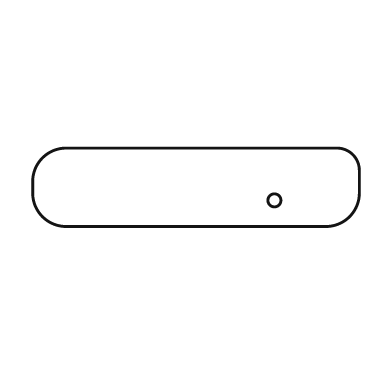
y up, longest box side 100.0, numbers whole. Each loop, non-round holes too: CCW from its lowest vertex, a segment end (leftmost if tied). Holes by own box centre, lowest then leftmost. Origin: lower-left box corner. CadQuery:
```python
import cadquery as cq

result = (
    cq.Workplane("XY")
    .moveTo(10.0, 0.0)
    .lineTo(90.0, 0.0)
    .threePointArc((97.0, 3.0), (100.0, 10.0))
    .lineTo(100.0, 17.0)
    .threePointArc((98.0, 22.0), (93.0, 24.0))
    .lineTo(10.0, 24.0)
    .threePointArc((3.0, 21.0), (0.0, 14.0))
    .lineTo(0.0, 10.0)
    .threePointArc((3.0, 3.0), (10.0, 0.0))
    .close()
    .moveTo(74.0, 8.0)
    .circle(2.0)
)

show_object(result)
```